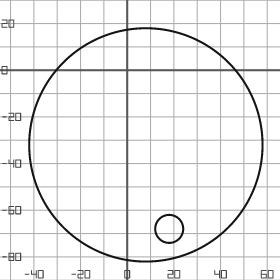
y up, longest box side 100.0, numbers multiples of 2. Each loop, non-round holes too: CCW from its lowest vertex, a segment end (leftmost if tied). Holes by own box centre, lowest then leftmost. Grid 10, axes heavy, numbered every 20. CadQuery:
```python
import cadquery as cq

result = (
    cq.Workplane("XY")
    .moveTo(8.0, -32.0)
    .circle(50.0)
    .moveTo(18.0, -68.0)
    .circle(6.0)
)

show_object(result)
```